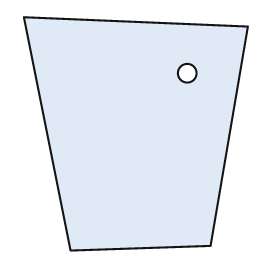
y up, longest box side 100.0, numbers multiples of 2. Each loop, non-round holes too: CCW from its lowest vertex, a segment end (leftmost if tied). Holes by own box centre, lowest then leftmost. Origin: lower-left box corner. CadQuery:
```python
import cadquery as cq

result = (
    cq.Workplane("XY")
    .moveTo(20.0, 0.0)
    .lineTo(80.0, 2.0)
    .lineTo(96.0, 96.0)
    .lineTo(0.0, 100.0)
    .close()
    .moveTo(70.0, 76.0)
    .circle(4.0)
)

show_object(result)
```